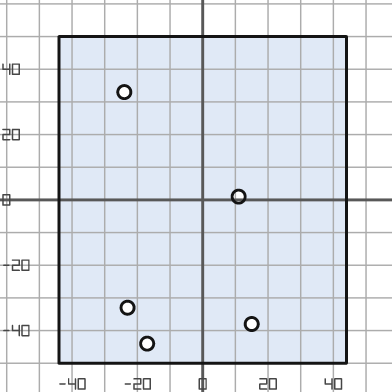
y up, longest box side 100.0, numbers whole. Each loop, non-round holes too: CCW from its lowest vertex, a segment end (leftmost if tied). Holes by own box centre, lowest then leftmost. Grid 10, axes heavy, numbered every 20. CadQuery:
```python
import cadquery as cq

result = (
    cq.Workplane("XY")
    .moveTo(-44.0, -50.0)
    .lineTo(44.0, -50.0)
    .lineTo(44.0, 50.0)
    .lineTo(-44.0, 50.0)
    .close()
    .moveTo(-17.0, -44.0)
    .circle(2.0)
    .moveTo(15.0, -38.0)
    .circle(2.0)
    .moveTo(-23.0, -33.0)
    .circle(2.0)
    .moveTo(11.0, 1.0)
    .circle(2.0)
    .moveTo(-24.0, 33.0)
    .circle(2.0)
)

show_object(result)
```